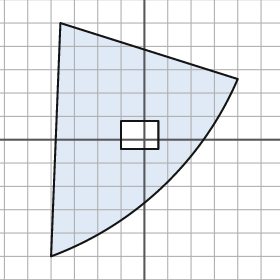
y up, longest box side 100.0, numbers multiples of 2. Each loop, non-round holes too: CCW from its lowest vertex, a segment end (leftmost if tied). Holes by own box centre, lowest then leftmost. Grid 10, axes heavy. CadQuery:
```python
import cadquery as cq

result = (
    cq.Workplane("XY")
    .moveTo(-40.0, -50.0)
    .threePointArc((8.0, -20.0), (40.0, 26.0))
    .lineTo(-36.0, 50.0)
    .close()
    .moveTo(-10.0, -4.0)
    .lineTo(6.0, -4.0)
    .lineTo(6.0, 8.0)
    .lineTo(-10.0, 8.0)
    .close()
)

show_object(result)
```